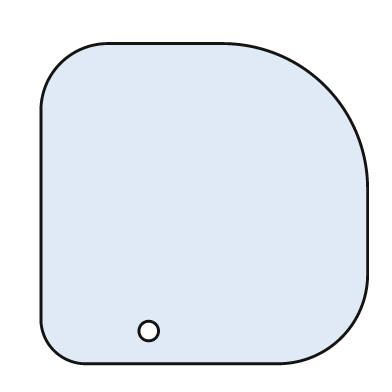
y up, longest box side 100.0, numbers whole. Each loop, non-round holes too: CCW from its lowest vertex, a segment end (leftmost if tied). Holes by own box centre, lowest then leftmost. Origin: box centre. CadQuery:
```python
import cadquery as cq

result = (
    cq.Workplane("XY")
    .moveTo(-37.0, -49.0)
    .lineTo(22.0, -49.0)
    .threePointArc((42.0, -41.0), (50.0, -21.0))
    .lineTo(50.0, 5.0)
    .threePointArc((37.0, 36.0), (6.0, 49.0))
    .lineTo(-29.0, 49.0)
    .threePointArc((-44.0, 43.0), (-50.0, 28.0))
    .lineTo(-50.0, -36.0)
    .threePointArc((-46.0, -45.0), (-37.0, -49.0))
    .close()
    .moveTo(-17.0, -39.0)
    .circle(3.0)
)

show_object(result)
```